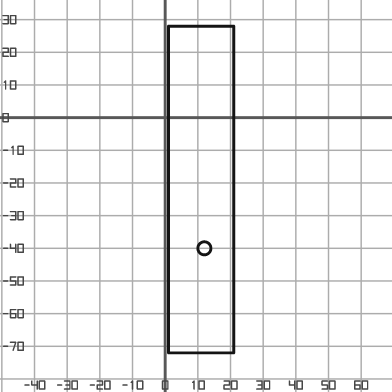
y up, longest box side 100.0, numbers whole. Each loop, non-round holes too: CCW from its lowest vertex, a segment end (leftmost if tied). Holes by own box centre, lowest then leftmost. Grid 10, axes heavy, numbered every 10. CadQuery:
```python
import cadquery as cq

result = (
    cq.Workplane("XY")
    .moveTo(1.0, -72.0)
    .lineTo(21.0, -72.0)
    .lineTo(21.0, 28.0)
    .lineTo(1.0, 28.0)
    .close()
    .moveTo(12.0, -40.0)
    .circle(2.0)
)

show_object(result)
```